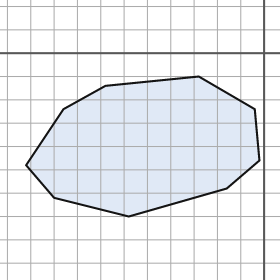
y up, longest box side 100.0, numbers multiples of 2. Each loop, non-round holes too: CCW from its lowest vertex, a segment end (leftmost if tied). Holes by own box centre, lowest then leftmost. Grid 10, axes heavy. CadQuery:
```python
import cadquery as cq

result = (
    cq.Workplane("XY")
    .moveTo(-58.0, -70.0)
    .lineTo(-16.0, -58.0)
    .lineTo(-2.0, -46.0)
    .lineTo(-4.0, -24.0)
    .lineTo(-28.0, -10.0)
    .lineTo(-68.0, -14.0)
    .lineTo(-86.0, -24.0)
    .lineTo(-102.0, -48.0)
    .lineTo(-90.0, -62.0)
    .close()
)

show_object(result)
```